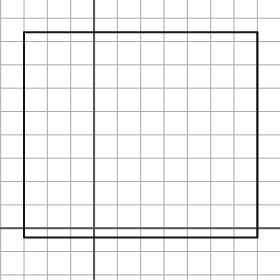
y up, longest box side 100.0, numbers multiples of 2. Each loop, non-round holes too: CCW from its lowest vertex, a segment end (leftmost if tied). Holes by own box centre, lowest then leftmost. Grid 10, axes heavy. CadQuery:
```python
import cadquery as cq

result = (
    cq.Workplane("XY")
    .moveTo(-30.0, -4.0)
    .lineTo(70.0, -4.0)
    .lineTo(70.0, 84.0)
    .lineTo(-30.0, 84.0)
    .close()
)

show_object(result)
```